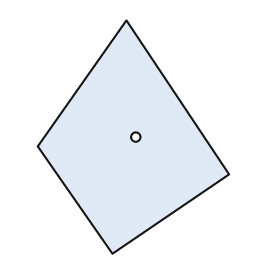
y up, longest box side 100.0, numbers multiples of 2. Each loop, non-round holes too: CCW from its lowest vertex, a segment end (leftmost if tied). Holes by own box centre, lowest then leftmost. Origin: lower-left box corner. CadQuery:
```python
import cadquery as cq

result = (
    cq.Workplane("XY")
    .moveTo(32.0, 0.0)
    .lineTo(82.0, 34.0)
    .lineTo(38.0, 100.0)
    .lineTo(0.0, 46.0)
    .close()
    .moveTo(42.0, 50.0)
    .circle(2.0)
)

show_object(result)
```